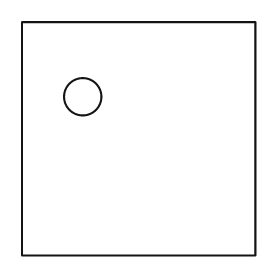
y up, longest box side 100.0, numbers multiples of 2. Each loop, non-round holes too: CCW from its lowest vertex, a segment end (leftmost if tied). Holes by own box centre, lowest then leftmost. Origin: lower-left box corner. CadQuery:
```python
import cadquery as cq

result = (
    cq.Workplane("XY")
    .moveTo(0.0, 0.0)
    .lineTo(100.0, 0.0)
    .lineTo(100.0, 100.0)
    .lineTo(0.0, 100.0)
    .close()
    .moveTo(26.0, 68.0)
    .circle(8.0)
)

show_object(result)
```